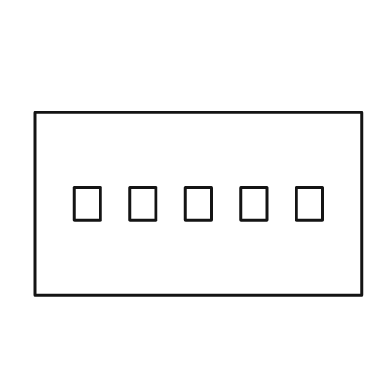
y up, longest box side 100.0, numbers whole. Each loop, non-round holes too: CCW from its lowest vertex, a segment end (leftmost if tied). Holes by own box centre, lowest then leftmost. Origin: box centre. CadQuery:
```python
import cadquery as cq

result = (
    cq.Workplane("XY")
    .moveTo(-50.0, -28.0)
    .lineTo(50.0, -28.0)
    .lineTo(50.0, 28.0)
    .lineTo(-50.0, 28.0)
    .close()
    .moveTo(-38.0, -5.0)
    .lineTo(-30.0, -5.0)
    .lineTo(-30.0, 5.0)
    .lineTo(-38.0, 5.0)
    .close()
    .moveTo(-21.0, -5.0)
    .lineTo(-13.0, -5.0)
    .lineTo(-13.0, 5.0)
    .lineTo(-21.0, 5.0)
    .close()
    .moveTo(-4.0, -5.0)
    .lineTo(4.0, -5.0)
    .lineTo(4.0, 5.0)
    .lineTo(-4.0, 5.0)
    .close()
    .moveTo(13.0, -5.0)
    .lineTo(21.0, -5.0)
    .lineTo(21.0, 5.0)
    .lineTo(13.0, 5.0)
    .close()
    .moveTo(30.0, -5.0)
    .lineTo(38.0, -5.0)
    .lineTo(38.0, 5.0)
    .lineTo(30.0, 5.0)
    .close()
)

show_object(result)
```